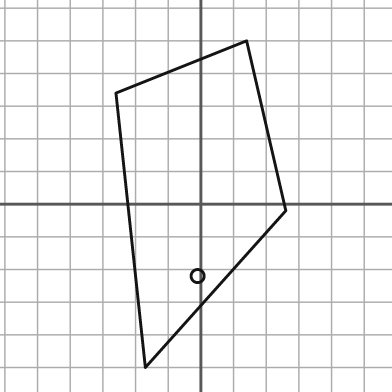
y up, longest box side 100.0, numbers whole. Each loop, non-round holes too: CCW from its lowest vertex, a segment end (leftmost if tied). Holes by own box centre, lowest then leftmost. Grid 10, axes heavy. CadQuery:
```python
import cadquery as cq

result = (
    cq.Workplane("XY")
    .moveTo(-17.0, -50.0)
    .lineTo(26.0, -2.0)
    .lineTo(14.0, 50.0)
    .lineTo(-26.0, 34.0)
    .close()
    .moveTo(-1.0, -22.0)
    .circle(2.0)
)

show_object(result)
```